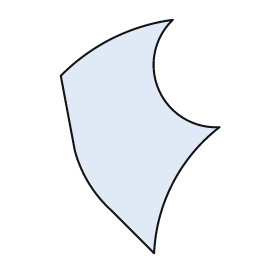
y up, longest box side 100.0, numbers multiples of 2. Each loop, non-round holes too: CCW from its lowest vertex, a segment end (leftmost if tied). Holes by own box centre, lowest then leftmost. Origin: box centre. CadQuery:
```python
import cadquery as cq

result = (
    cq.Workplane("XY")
    .moveTo(6.0, -50.0)
    .threePointArc((14.0, -20.0), (34.0, 4.0))
    .threePointArc((8.0, 20.0), (14.0, 50.0))
    .threePointArc((-12.0, 42.0), (-34.0, 26.0))
    .lineTo(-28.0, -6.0)
    .threePointArc((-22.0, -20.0), (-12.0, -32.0))
    .close()
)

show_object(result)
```